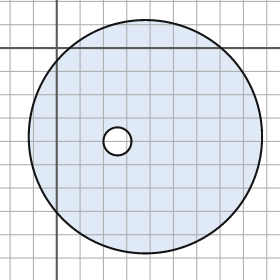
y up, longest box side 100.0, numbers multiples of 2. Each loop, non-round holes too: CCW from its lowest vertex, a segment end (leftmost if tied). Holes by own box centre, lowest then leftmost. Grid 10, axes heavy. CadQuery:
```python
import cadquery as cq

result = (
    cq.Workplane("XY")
    .moveTo(38.0, -38.0)
    .circle(50.0)
    .moveTo(26.0, -40.0)
    .circle(6.0)
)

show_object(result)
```